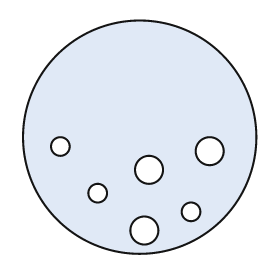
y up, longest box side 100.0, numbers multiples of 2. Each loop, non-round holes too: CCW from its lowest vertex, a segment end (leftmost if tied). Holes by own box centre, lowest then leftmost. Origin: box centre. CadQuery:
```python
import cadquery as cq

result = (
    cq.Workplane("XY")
    .moveTo(0.0, 0.0)
    .circle(50.0)
    .moveTo(2.0, -40.0)
    .circle(6.0)
    .moveTo(22.0, -32.0)
    .circle(4.0)
    .moveTo(-18.0, -24.0)
    .circle(4.0)
    .moveTo(4.0, -14.0)
    .circle(6.0)
    .moveTo(30.0, -6.0)
    .circle(6.0)
    .moveTo(-34.0, -4.0)
    .circle(4.0)
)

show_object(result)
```